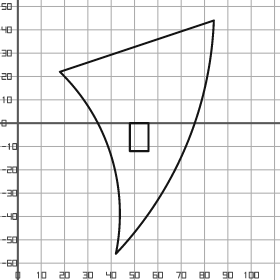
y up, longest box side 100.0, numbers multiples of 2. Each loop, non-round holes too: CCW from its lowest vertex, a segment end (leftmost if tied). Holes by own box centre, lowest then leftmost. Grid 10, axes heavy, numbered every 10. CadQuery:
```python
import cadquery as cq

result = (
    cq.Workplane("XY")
    .moveTo(42.0, -56.0)
    .threePointArc((72.0, -10.0), (84.0, 44.0))
    .lineTo(18.0, 22.0)
    .threePointArc((40.0, -14.0), (42.0, -56.0))
    .close()
    .moveTo(48.0, -12.0)
    .lineTo(56.0, -12.0)
    .lineTo(56.0, 0.0)
    .lineTo(48.0, 0.0)
    .close()
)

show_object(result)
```